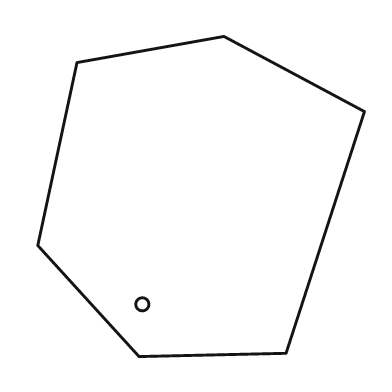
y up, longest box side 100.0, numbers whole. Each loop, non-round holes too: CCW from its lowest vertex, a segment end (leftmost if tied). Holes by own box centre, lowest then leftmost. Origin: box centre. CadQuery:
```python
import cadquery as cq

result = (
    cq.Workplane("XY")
    .moveTo(-19.0, -49.0)
    .lineTo(26.0, -48.0)
    .lineTo(50.0, 26.0)
    .lineTo(7.0, 49.0)
    .lineTo(-38.0, 41.0)
    .lineTo(-50.0, -15.0)
    .close()
    .moveTo(-18.0, -33.0)
    .circle(2.0)
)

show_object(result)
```